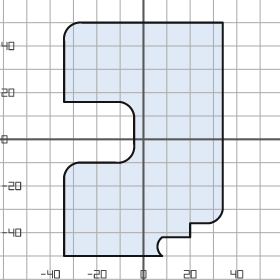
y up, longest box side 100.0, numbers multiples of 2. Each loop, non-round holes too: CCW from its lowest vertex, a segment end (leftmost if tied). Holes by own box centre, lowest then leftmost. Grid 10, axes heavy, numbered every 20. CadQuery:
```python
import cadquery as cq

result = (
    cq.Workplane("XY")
    .moveTo(-34.0, -50.0)
    .lineTo(8.0, -50.0)
    .threePointArc((6.0, -46.0), (8.0, -42.0))
    .lineTo(20.0, -42.0)
    .lineTo(20.0, -36.0)
    .lineTo(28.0, -36.0)
    .threePointArc((32.0, -34.0), (34.0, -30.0))
    .lineTo(34.0, 50.0)
    .lineTo(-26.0, 50.0)
    .threePointArc((-32.0, 48.0), (-34.0, 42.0))
    .lineTo(-34.0, 16.0)
    .lineTo(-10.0, 16.0)
    .threePointArc((-6.0, 14.0), (-4.0, 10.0))
    .lineTo(-4.0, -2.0)
    .threePointArc((-6.0, -8.0), (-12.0, -10.0))
    .lineTo(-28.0, -10.0)
    .threePointArc((-32.0, -12.0), (-34.0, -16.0))
    .close()
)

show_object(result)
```